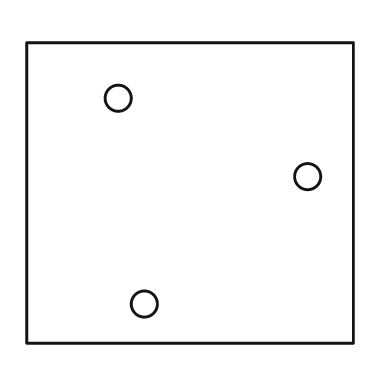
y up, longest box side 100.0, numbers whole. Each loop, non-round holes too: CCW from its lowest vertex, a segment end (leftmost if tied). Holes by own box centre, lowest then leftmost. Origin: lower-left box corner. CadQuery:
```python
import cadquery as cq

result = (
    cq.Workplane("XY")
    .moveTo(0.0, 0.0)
    .lineTo(100.0, 0.0)
    .lineTo(100.0, 92.0)
    .lineTo(0.0, 92.0)
    .close()
    .moveTo(36.0, 12.0)
    .circle(4.0)
    .moveTo(86.0, 51.0)
    .circle(4.0)
    .moveTo(28.0, 75.0)
    .circle(4.0)
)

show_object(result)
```